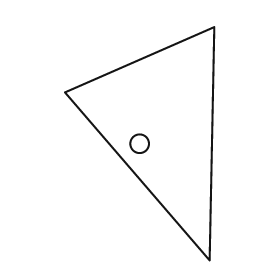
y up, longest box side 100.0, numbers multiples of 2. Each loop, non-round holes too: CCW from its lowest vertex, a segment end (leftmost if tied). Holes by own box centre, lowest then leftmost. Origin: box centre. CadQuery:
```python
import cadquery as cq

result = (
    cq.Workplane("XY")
    .moveTo(30.0, -50.0)
    .lineTo(32.0, 50.0)
    .lineTo(-32.0, 22.0)
    .close()
    .moveTo(0.0, 0.0)
    .circle(4.0)
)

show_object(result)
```